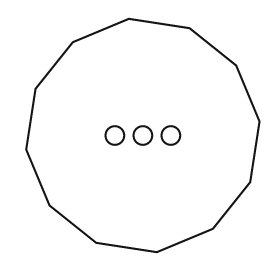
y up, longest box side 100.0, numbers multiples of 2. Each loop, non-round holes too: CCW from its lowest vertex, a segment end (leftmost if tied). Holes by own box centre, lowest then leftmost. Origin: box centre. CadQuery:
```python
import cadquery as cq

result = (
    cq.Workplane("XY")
    .moveTo(6.0, -50.0)
    .lineTo(30.0, -40.0)
    .lineTo(46.0, -20.0)
    .lineTo(50.0, 6.0)
    .lineTo(40.0, 30.0)
    .lineTo(20.0, 46.0)
    .lineTo(-6.0, 50.0)
    .lineTo(-30.0, 40.0)
    .lineTo(-46.0, 20.0)
    .lineTo(-50.0, -6.0)
    .lineTo(-40.0, -30.0)
    .lineTo(-20.0, -46.0)
    .close()
    .moveTo(-12.0, 0.0)
    .circle(4.0)
    .moveTo(0.0, 0.0)
    .circle(4.0)
    .moveTo(12.0, 0.0)
    .circle(4.0)
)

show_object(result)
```